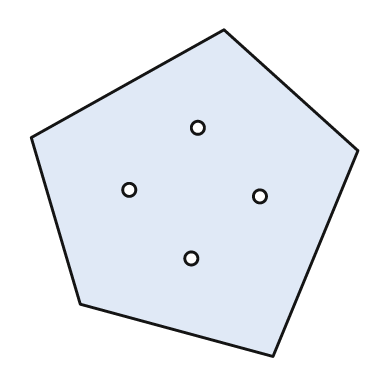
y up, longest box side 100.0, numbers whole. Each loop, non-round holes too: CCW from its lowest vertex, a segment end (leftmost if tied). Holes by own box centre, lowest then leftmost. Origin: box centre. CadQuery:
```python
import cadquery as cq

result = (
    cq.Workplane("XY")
    .moveTo(24.0, -50.0)
    .lineTo(50.0, 13.0)
    .lineTo(9.0, 50.0)
    .lineTo(-50.0, 17.0)
    .lineTo(-35.0, -34.0)
    .close()
    .moveTo(-1.0, -20.0)
    .circle(2.0)
    .moveTo(20.0, -1.0)
    .circle(2.0)
    .moveTo(-20.0, 1.0)
    .circle(2.0)
    .moveTo(1.0, 20.0)
    .circle(2.0)
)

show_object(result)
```